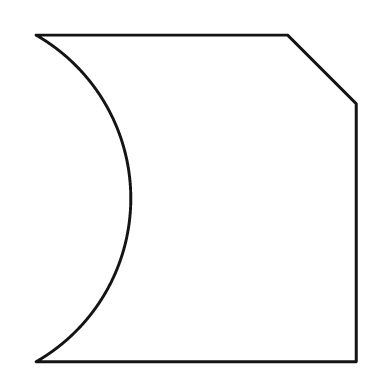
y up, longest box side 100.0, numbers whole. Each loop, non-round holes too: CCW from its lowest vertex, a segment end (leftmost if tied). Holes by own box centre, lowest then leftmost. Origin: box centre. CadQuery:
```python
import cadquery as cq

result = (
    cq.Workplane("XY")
    .moveTo(-49.0, -50.0)
    .lineTo(49.0, -50.0)
    .lineTo(49.0, 29.0)
    .lineTo(28.0, 50.0)
    .lineTo(-49.0, 50.0)
    .threePointArc((-20.0, 0.0), (-49.0, -50.0))
    .close()
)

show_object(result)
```